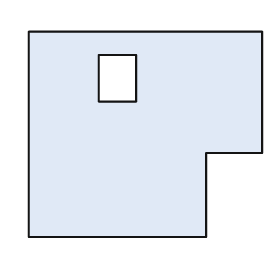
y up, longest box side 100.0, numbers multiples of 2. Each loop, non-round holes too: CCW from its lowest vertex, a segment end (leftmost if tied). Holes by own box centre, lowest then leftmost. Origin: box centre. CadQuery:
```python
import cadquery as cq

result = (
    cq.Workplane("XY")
    .moveTo(-50.0, -44.0)
    .lineTo(26.0, -44.0)
    .lineTo(26.0, -8.0)
    .lineTo(50.0, -8.0)
    .lineTo(50.0, 44.0)
    .lineTo(-50.0, 44.0)
    .close()
    .moveTo(-20.0, 14.0)
    .lineTo(-4.0, 14.0)
    .lineTo(-4.0, 34.0)
    .lineTo(-20.0, 34.0)
    .close()
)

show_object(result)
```